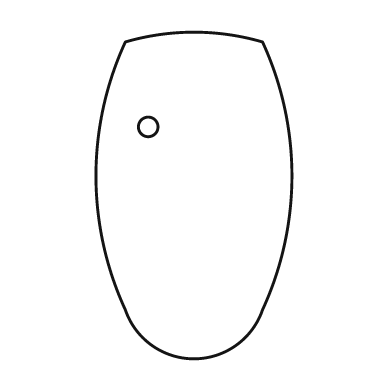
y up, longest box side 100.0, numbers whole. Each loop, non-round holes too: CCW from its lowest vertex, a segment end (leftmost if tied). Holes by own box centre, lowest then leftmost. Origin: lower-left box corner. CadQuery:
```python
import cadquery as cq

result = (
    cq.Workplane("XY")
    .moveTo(9.0, 15.0)
    .threePointArc((30.0, 0.0), (51.0, 15.0))
    .threePointArc((60.0, 56.0), (51.0, 97.0))
    .threePointArc((30.0, 100.0), (9.0, 97.0))
    .threePointArc((0.0, 56.0), (9.0, 15.0))
    .close()
    .moveTo(16.0, 71.0)
    .circle(3.0)
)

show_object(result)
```